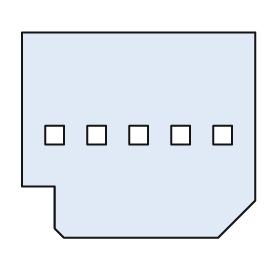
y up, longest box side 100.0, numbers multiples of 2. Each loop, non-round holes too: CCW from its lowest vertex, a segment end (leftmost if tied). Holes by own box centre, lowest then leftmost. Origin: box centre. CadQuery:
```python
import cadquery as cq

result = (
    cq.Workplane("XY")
    .moveTo(-32.0, -44.0)
    .lineTo(34.0, -44.0)
    .lineTo(50.0, -28.0)
    .lineTo(50.0, 44.0)
    .lineTo(-50.0, 44.0)
    .lineTo(-50.0, -22.0)
    .lineTo(-36.0, -22.0)
    .lineTo(-36.0, -40.0)
    .close()
    .moveTo(-40.0, -4.0)
    .lineTo(-32.0, -4.0)
    .lineTo(-32.0, 4.0)
    .lineTo(-40.0, 4.0)
    .close()
    .moveTo(-22.0, -4.0)
    .lineTo(-14.0, -4.0)
    .lineTo(-14.0, 4.0)
    .lineTo(-22.0, 4.0)
    .close()
    .moveTo(-4.0, -4.0)
    .lineTo(4.0, -4.0)
    .lineTo(4.0, 4.0)
    .lineTo(-4.0, 4.0)
    .close()
    .moveTo(14.0, -4.0)
    .lineTo(22.0, -4.0)
    .lineTo(22.0, 4.0)
    .lineTo(14.0, 4.0)
    .close()
    .moveTo(32.0, -4.0)
    .lineTo(40.0, -4.0)
    .lineTo(40.0, 4.0)
    .lineTo(32.0, 4.0)
    .close()
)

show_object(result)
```